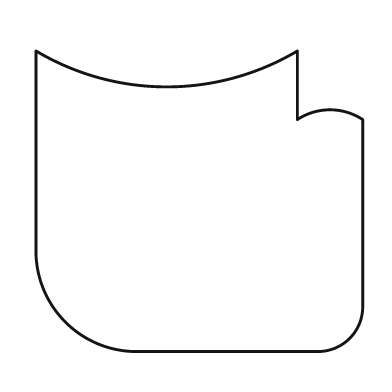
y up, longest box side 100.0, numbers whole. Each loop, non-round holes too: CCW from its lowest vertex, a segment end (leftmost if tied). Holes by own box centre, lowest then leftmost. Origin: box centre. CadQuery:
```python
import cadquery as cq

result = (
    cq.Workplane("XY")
    .moveTo(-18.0, -46.0)
    .lineTo(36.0, -46.0)
    .threePointArc((46.0, -42.0), (50.0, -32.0))
    .lineTo(50.0, 25.0)
    .threePointArc((40.0, 28.0), (30.0, 25.0))
    .lineTo(30.0, 46.0)
    .threePointArc((-10.0, 35.0), (-50.0, 46.0))
    .lineTo(-50.0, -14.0)
    .threePointArc((-41.0, -37.0), (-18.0, -46.0))
    .close()
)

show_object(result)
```